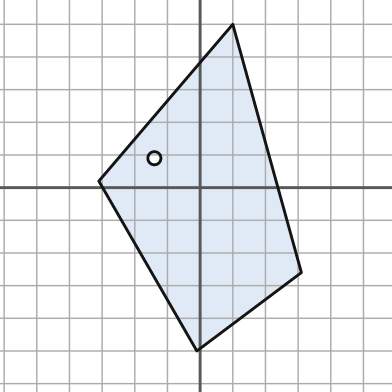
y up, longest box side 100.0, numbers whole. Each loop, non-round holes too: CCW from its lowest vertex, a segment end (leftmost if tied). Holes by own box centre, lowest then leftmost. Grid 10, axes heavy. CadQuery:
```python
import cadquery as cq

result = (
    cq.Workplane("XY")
    .moveTo(-1.0, -50.0)
    .lineTo(31.0, -26.0)
    .lineTo(10.0, 50.0)
    .lineTo(-31.0, 2.0)
    .close()
    .moveTo(-14.0, 9.0)
    .circle(2.0)
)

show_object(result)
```